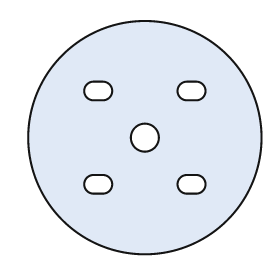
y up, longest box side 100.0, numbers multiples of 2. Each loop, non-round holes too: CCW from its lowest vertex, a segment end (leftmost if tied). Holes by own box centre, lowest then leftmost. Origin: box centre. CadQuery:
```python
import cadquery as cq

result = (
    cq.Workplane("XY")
    .moveTo(0.0, 0.0)
    .circle(50.0)
    .moveTo(-22.0, -24.0)
    .lineTo(-18.0, -24.0)
    .threePointArc((-14.0, -20.0), (-18.0, -16.0))
    .lineTo(-22.0, -16.0)
    .threePointArc((-26.0, -20.0), (-22.0, -24.0))
    .close()
    .moveTo(18.0, -24.0)
    .lineTo(22.0, -24.0)
    .threePointArc((26.0, -20.0), (22.0, -16.0))
    .lineTo(18.0, -16.0)
    .threePointArc((14.0, -20.0), (18.0, -24.0))
    .close()
    .moveTo(0.0, 0.0)
    .circle(6.0)
    .moveTo(-22.0, 16.0)
    .lineTo(-18.0, 16.0)
    .threePointArc((-14.0, 20.0), (-18.0, 24.0))
    .lineTo(-22.0, 24.0)
    .threePointArc((-26.0, 20.0), (-22.0, 16.0))
    .close()
    .moveTo(18.0, 16.0)
    .lineTo(22.0, 16.0)
    .threePointArc((26.0, 20.0), (22.0, 24.0))
    .lineTo(18.0, 24.0)
    .threePointArc((14.0, 20.0), (18.0, 16.0))
    .close()
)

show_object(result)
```